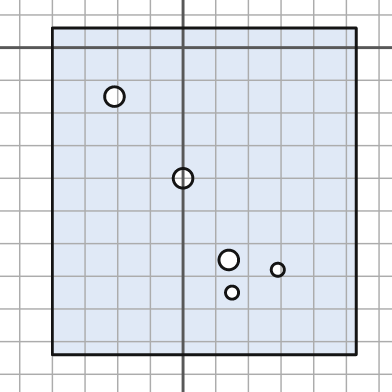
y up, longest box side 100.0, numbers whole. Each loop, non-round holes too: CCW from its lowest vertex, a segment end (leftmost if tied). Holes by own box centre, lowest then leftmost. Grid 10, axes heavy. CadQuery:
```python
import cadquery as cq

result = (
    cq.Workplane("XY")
    .moveTo(-40.0, -94.0)
    .lineTo(53.0, -94.0)
    .lineTo(53.0, 6.0)
    .lineTo(-40.0, 6.0)
    .close()
    .moveTo(15.0, -75.0)
    .circle(2.0)
    .moveTo(29.0, -68.0)
    .circle(2.0)
    .moveTo(14.0, -65.0)
    .circle(3.0)
    .moveTo(0.0, -40.0)
    .circle(3.0)
    .moveTo(-21.0, -15.0)
    .circle(3.0)
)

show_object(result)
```